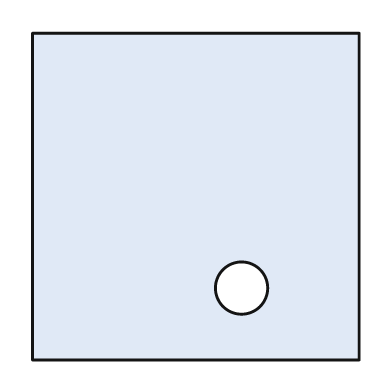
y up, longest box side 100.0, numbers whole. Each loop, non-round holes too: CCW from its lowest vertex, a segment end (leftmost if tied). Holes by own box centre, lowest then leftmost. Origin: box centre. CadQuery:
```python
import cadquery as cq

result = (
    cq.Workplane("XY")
    .moveTo(-50.0, -50.0)
    .lineTo(50.0, -50.0)
    .lineTo(50.0, 50.0)
    .lineTo(-50.0, 50.0)
    .close()
    .moveTo(14.0, -28.0)
    .circle(8.0)
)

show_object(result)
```